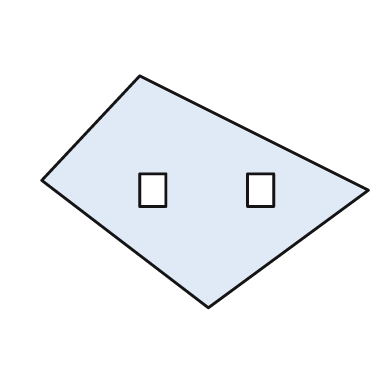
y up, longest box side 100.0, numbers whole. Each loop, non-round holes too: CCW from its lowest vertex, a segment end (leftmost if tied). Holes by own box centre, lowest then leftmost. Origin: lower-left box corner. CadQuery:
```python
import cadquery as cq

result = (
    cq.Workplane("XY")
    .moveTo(51.0, 0.0)
    .lineTo(100.0, 36.0)
    .lineTo(30.0, 71.0)
    .lineTo(0.0, 39.0)
    .close()
    .moveTo(30.0, 31.0)
    .lineTo(38.0, 31.0)
    .lineTo(38.0, 41.0)
    .lineTo(30.0, 41.0)
    .close()
    .moveTo(63.0, 31.0)
    .lineTo(71.0, 31.0)
    .lineTo(71.0, 41.0)
    .lineTo(63.0, 41.0)
    .close()
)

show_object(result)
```